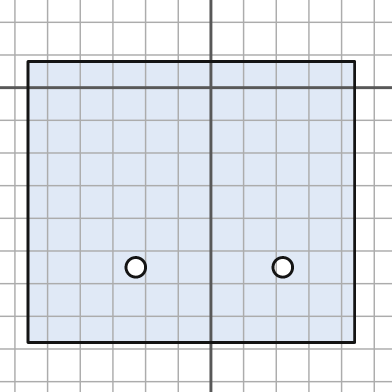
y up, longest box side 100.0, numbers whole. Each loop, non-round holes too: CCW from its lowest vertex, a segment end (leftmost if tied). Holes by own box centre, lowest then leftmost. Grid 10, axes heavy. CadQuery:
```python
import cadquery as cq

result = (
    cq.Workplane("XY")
    .moveTo(-56.0, -78.0)
    .lineTo(44.0, -78.0)
    .lineTo(44.0, 8.0)
    .lineTo(-56.0, 8.0)
    .close()
    .moveTo(-23.0, -55.0)
    .circle(3.0)
    .moveTo(22.0, -55.0)
    .circle(3.0)
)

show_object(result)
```